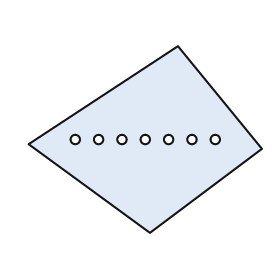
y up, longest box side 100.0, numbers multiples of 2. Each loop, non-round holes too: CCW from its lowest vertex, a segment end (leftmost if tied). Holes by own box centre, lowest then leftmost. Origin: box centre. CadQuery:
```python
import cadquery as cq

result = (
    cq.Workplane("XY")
    .moveTo(2.0, -40.0)
    .lineTo(50.0, -4.0)
    .lineTo(14.0, 40.0)
    .lineTo(-50.0, -2.0)
    .close()
    .moveTo(-30.0, 0.0)
    .circle(2.0)
    .moveTo(-20.0, 0.0)
    .circle(2.0)
    .moveTo(-10.0, 0.0)
    .circle(2.0)
    .moveTo(0.0, 0.0)
    .circle(2.0)
    .moveTo(10.0, 0.0)
    .circle(2.0)
    .moveTo(20.0, 0.0)
    .circle(2.0)
    .moveTo(30.0, 0.0)
    .circle(2.0)
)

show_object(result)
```